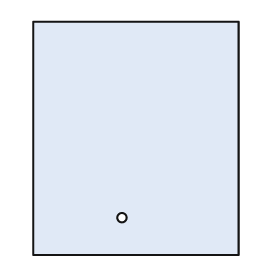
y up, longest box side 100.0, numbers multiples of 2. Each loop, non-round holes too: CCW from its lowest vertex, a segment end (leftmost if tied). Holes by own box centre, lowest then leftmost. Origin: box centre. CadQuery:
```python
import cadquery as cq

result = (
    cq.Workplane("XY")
    .moveTo(-44.0, -50.0)
    .lineTo(44.0, -50.0)
    .lineTo(44.0, 50.0)
    .lineTo(-44.0, 50.0)
    .close()
    .moveTo(-6.0, -34.0)
    .circle(2.0)
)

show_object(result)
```